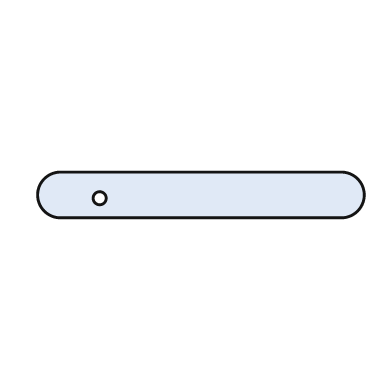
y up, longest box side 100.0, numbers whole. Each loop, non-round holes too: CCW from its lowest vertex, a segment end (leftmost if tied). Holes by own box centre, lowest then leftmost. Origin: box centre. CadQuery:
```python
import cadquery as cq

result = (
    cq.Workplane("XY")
    .moveTo(-43.0, -7.0)
    .lineTo(43.0, -7.0)
    .threePointArc((50.0, 0.0), (43.0, 7.0))
    .lineTo(-43.0, 7.0)
    .threePointArc((-50.0, 0.0), (-43.0, -7.0))
    .close()
    .moveTo(-31.0, -1.0)
    .circle(2.0)
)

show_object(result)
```